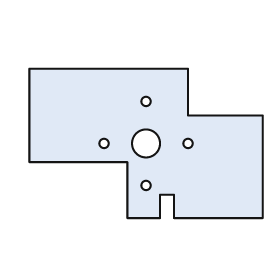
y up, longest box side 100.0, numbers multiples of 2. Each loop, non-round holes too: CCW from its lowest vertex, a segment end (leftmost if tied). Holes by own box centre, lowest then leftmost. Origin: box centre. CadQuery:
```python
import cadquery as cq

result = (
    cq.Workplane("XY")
    .moveTo(-8.0, -32.0)
    .lineTo(6.0, -32.0)
    .lineTo(6.0, -22.0)
    .lineTo(12.0, -22.0)
    .lineTo(12.0, -32.0)
    .lineTo(50.0, -32.0)
    .lineTo(50.0, 12.0)
    .lineTo(18.0, 12.0)
    .lineTo(18.0, 32.0)
    .lineTo(-50.0, 32.0)
    .lineTo(-50.0, -8.0)
    .lineTo(-8.0, -8.0)
    .close()
    .moveTo(0.0, -18.0)
    .circle(2.0)
    .moveTo(-18.0, 0.0)
    .circle(2.0)
    .moveTo(0.0, 0.0)
    .circle(6.0)
    .moveTo(18.0, 0.0)
    .circle(2.0)
    .moveTo(0.0, 18.0)
    .circle(2.0)
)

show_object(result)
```